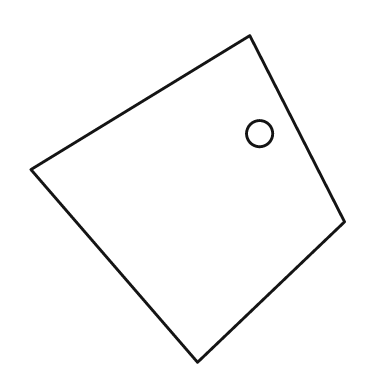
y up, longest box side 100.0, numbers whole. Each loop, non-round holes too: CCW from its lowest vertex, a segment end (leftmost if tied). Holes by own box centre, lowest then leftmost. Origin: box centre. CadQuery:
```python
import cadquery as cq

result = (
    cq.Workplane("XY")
    .moveTo(3.0, -50.0)
    .lineTo(48.0, -7.0)
    .lineTo(19.0, 50.0)
    .lineTo(-48.0, 9.0)
    .close()
    .moveTo(22.0, 20.0)
    .circle(4.0)
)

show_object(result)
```